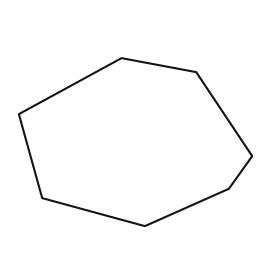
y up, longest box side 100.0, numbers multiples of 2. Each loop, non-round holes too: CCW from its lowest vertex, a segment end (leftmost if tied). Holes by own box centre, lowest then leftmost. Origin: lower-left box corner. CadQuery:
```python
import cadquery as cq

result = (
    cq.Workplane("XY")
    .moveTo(54.0, 0.0)
    .lineTo(90.0, 16.0)
    .lineTo(100.0, 30.0)
    .lineTo(76.0, 66.0)
    .lineTo(44.0, 72.0)
    .lineTo(0.0, 48.0)
    .lineTo(10.0, 12.0)
    .close()
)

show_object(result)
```